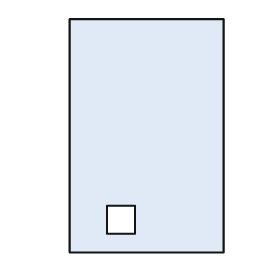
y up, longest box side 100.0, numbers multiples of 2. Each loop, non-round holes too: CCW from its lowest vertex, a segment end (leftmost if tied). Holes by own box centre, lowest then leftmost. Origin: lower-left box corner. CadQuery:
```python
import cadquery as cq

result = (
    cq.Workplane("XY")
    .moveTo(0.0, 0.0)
    .lineTo(66.0, 0.0)
    .lineTo(66.0, 100.0)
    .lineTo(0.0, 100.0)
    .close()
    .moveTo(16.0, 8.0)
    .lineTo(28.0, 8.0)
    .lineTo(28.0, 20.0)
    .lineTo(16.0, 20.0)
    .close()
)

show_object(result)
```